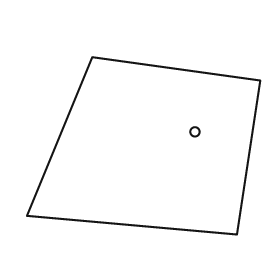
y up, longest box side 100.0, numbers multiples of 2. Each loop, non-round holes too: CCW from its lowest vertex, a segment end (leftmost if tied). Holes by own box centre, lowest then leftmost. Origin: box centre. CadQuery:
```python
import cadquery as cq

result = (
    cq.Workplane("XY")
    .moveTo(40.0, -38.0)
    .lineTo(50.0, 28.0)
    .lineTo(-22.0, 38.0)
    .lineTo(-50.0, -30.0)
    .close()
    .moveTo(22.0, 6.0)
    .circle(2.0)
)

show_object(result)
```